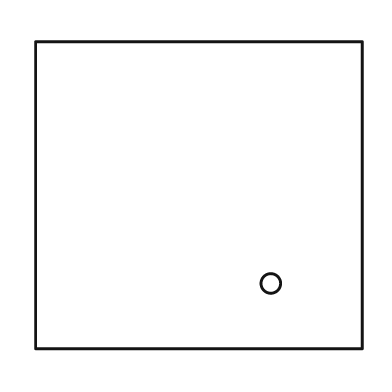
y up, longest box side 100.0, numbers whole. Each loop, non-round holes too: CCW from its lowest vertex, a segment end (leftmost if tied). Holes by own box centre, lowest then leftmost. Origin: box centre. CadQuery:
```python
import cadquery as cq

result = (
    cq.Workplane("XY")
    .moveTo(-50.0, -47.0)
    .lineTo(50.0, -47.0)
    .lineTo(50.0, 47.0)
    .lineTo(-50.0, 47.0)
    .close()
    .moveTo(22.0, -27.0)
    .circle(3.0)
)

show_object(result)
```